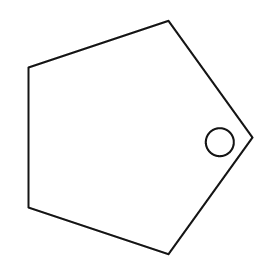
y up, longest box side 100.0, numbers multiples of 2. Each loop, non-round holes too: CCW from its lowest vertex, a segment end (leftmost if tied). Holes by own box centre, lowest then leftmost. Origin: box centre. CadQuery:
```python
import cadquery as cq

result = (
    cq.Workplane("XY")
    .moveTo(12.0, -50.0)
    .lineTo(48.0, 0.0)
    .lineTo(12.0, 50.0)
    .lineTo(-48.0, 30.0)
    .lineTo(-48.0, -30.0)
    .close()
    .moveTo(34.0, -2.0)
    .circle(6.0)
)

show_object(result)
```